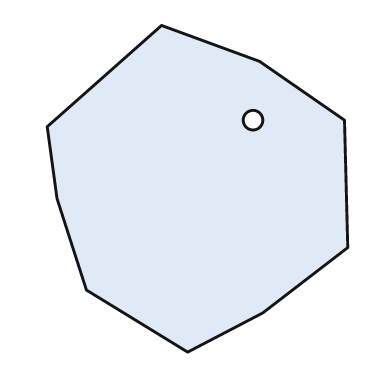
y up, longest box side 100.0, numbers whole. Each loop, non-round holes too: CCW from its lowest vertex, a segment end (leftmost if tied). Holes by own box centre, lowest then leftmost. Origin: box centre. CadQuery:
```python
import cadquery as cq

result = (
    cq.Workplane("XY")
    .moveTo(-3.0, -50.0)
    .lineTo(20.0, -38.0)
    .lineTo(46.0, -18.0)
    .lineTo(45.0, 21.0)
    .lineTo(19.0, 39.0)
    .lineTo(-11.0, 50.0)
    .lineTo(-46.0, 19.0)
    .lineTo(-43.0, -3.0)
    .lineTo(-34.0, -31.0)
    .close()
    .moveTo(17.0, 21.0)
    .circle(3.0)
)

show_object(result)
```